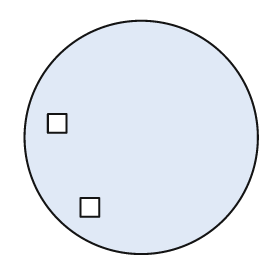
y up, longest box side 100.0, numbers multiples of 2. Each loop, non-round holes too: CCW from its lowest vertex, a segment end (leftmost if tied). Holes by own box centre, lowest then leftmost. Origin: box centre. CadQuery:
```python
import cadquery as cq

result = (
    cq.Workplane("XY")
    .moveTo(0.0, 0.0)
    .circle(50.0)
    .moveTo(-26.0, -34.0)
    .lineTo(-18.0, -34.0)
    .lineTo(-18.0, -26.0)
    .lineTo(-26.0, -26.0)
    .close()
    .moveTo(-40.0, 2.0)
    .lineTo(-32.0, 2.0)
    .lineTo(-32.0, 10.0)
    .lineTo(-40.0, 10.0)
    .close()
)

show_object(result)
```